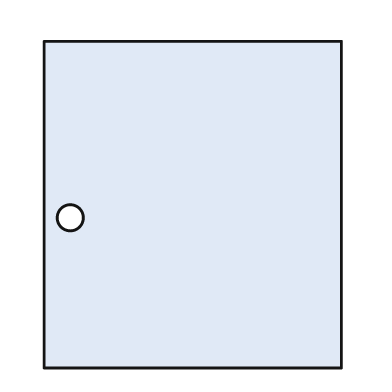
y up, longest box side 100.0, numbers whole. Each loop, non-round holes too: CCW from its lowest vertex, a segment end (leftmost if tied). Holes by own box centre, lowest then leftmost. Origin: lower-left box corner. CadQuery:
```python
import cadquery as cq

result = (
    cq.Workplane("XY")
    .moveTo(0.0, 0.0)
    .lineTo(91.0, 0.0)
    .lineTo(91.0, 100.0)
    .lineTo(0.0, 100.0)
    .close()
    .moveTo(8.0, 46.0)
    .circle(4.0)
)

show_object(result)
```